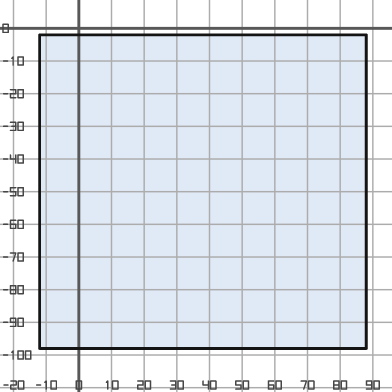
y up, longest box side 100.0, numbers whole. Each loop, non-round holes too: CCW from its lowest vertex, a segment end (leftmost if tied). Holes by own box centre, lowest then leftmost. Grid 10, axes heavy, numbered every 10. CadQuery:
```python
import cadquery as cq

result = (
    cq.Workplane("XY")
    .moveTo(-12.0, -98.0)
    .lineTo(88.0, -98.0)
    .lineTo(88.0, -2.0)
    .lineTo(-12.0, -2.0)
    .close()
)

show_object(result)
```